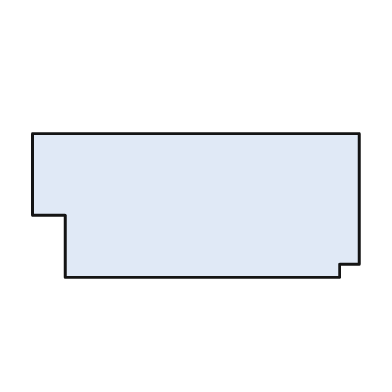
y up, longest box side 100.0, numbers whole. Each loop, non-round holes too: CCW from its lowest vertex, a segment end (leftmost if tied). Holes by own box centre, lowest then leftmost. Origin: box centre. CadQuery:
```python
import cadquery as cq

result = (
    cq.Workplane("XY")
    .moveTo(-40.0, -22.0)
    .lineTo(44.0, -22.0)
    .lineTo(44.0, -18.0)
    .lineTo(50.0, -18.0)
    .lineTo(50.0, 22.0)
    .lineTo(-50.0, 22.0)
    .lineTo(-50.0, -3.0)
    .lineTo(-40.0, -3.0)
    .close()
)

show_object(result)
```